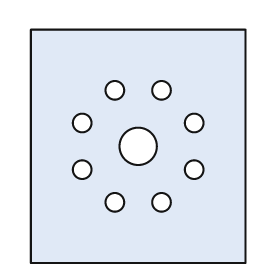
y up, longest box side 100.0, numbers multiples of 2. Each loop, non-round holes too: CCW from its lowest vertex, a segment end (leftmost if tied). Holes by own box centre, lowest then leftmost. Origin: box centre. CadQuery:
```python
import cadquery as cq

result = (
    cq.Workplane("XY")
    .moveTo(-46.0, -50.0)
    .lineTo(46.0, -50.0)
    .lineTo(46.0, 50.0)
    .lineTo(-46.0, 50.0)
    .close()
    .moveTo(-10.0, -24.0)
    .circle(4.0)
    .moveTo(10.0, -24.0)
    .circle(4.0)
    .moveTo(-24.0, -10.0)
    .circle(4.0)
    .moveTo(24.0, -10.0)
    .circle(4.0)
    .moveTo(0.0, 0.0)
    .circle(8.0)
    .moveTo(-24.0, 10.0)
    .circle(4.0)
    .moveTo(24.0, 10.0)
    .circle(4.0)
    .moveTo(-10.0, 24.0)
    .circle(4.0)
    .moveTo(10.0, 24.0)
    .circle(4.0)
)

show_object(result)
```